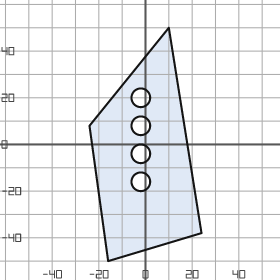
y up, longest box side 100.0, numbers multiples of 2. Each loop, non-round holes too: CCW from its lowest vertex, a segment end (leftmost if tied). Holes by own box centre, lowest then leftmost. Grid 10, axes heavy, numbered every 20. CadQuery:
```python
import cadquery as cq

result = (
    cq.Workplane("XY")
    .moveTo(-16.0, -50.0)
    .lineTo(24.0, -38.0)
    .lineTo(10.0, 50.0)
    .lineTo(-24.0, 8.0)
    .close()
    .moveTo(-2.0, -16.0)
    .circle(4.0)
    .moveTo(-2.0, -4.0)
    .circle(4.0)
    .moveTo(-2.0, 8.0)
    .circle(4.0)
    .moveTo(-2.0, 20.0)
    .circle(4.0)
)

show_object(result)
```